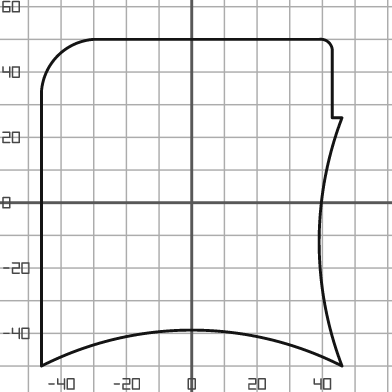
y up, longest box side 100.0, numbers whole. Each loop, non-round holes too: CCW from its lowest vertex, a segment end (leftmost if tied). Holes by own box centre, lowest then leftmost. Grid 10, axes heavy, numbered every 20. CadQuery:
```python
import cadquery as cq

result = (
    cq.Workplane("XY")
    .moveTo(-46.0, -50.0)
    .threePointArc((0.0, -39.0), (46.0, -50.0))
    .threePointArc((39.0, -12.0), (46.0, 26.0))
    .lineTo(43.0, 26.0)
    .lineTo(43.0, 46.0)
    .threePointArc((42.0, 49.0), (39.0, 50.0))
    .lineTo(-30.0, 50.0)
    .threePointArc((-41.0, 45.0), (-46.0, 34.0))
    .close()
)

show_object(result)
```